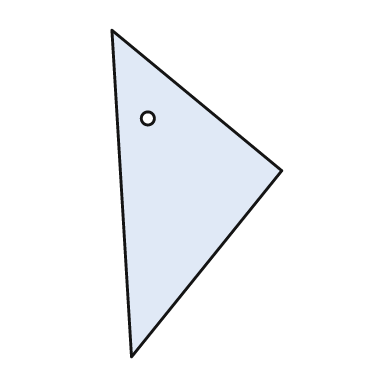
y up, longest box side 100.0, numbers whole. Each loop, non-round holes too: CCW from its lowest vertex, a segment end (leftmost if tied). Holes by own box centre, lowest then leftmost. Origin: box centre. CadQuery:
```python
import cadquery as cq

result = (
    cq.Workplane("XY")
    .moveTo(-20.0, -50.0)
    .lineTo(26.0, 7.0)
    .lineTo(-26.0, 50.0)
    .close()
    .moveTo(-15.0, 23.0)
    .circle(2.0)
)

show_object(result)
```